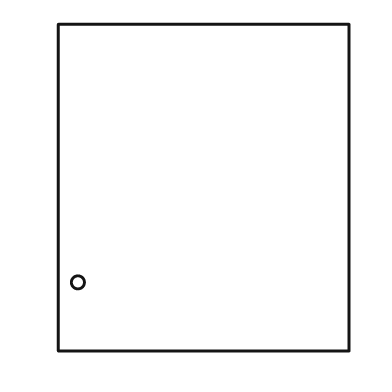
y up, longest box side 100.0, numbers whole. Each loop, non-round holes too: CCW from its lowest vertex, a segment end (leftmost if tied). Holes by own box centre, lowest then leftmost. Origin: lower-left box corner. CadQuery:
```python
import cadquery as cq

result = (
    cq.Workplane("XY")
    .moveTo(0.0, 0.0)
    .lineTo(89.0, 0.0)
    .lineTo(89.0, 100.0)
    .lineTo(0.0, 100.0)
    .close()
    .moveTo(6.0, 21.0)
    .circle(2.0)
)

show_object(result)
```